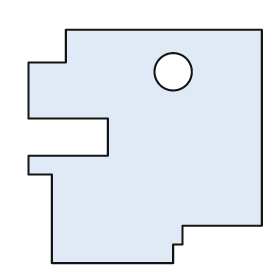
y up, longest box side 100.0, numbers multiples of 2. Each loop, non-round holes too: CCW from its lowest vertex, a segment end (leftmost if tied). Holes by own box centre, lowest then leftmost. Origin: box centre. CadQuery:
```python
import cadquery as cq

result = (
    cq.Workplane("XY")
    .moveTo(-40.0, -50.0)
    .lineTo(12.0, -50.0)
    .lineTo(12.0, -42.0)
    .lineTo(16.0, -42.0)
    .lineTo(16.0, -34.0)
    .lineTo(50.0, -34.0)
    .lineTo(50.0, 50.0)
    .lineTo(-34.0, 50.0)
    .lineTo(-34.0, 36.0)
    .lineTo(-50.0, 36.0)
    .lineTo(-50.0, 12.0)
    .lineTo(-16.0, 12.0)
    .lineTo(-16.0, -4.0)
    .lineTo(-50.0, -4.0)
    .lineTo(-50.0, -12.0)
    .lineTo(-40.0, -12.0)
    .close()
    .moveTo(12.0, 32.0)
    .circle(8.0)
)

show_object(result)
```